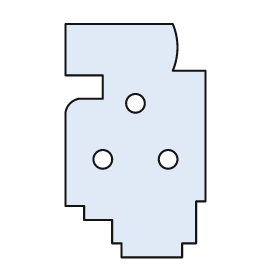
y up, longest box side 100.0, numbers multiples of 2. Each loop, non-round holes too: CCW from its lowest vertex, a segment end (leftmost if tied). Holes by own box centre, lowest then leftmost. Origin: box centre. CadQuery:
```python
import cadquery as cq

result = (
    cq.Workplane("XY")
    .moveTo(-6.0, -50.0)
    .lineTo(20.0, -50.0)
    .lineTo(20.0, -44.0)
    .lineTo(26.0, -44.0)
    .lineTo(26.0, -26.0)
    .lineTo(30.0, -26.0)
    .lineTo(30.0, 30.0)
    .lineTo(16.0, 30.0)
    .threePointArc((18.0, 40.0), (16.0, 50.0))
    .lineTo(-30.0, 50.0)
    .lineTo(-30.0, 28.0)
    .lineTo(-14.0, 28.0)
    .lineTo(-14.0, 18.0)
    .lineTo(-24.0, 18.0)
    .threePointArc((-28.0, 16.0), (-30.0, 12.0))
    .lineTo(-30.0, -28.0)
    .lineTo(-22.0, -28.0)
    .lineTo(-22.0, -34.0)
    .lineTo(-10.0, -34.0)
    .lineTo(-10.0, -44.0)
    .lineTo(-6.0, -44.0)
    .close()
    .moveTo(-14.0, -8.0)
    .circle(4.0)
    .moveTo(14.0, -8.0)
    .circle(4.0)
    .moveTo(0.0, 16.0)
    .circle(4.0)
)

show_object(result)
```